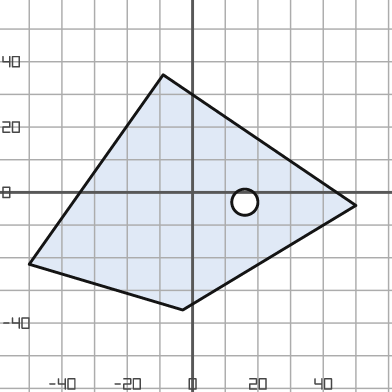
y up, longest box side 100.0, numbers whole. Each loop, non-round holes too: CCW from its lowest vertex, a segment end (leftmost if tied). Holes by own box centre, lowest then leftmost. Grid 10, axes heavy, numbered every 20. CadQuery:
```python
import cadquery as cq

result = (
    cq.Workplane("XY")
    .moveTo(-3.0, -36.0)
    .lineTo(50.0, -4.0)
    .lineTo(-9.0, 36.0)
    .lineTo(-50.0, -22.0)
    .close()
    .moveTo(16.0, -3.0)
    .circle(4.0)
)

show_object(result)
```